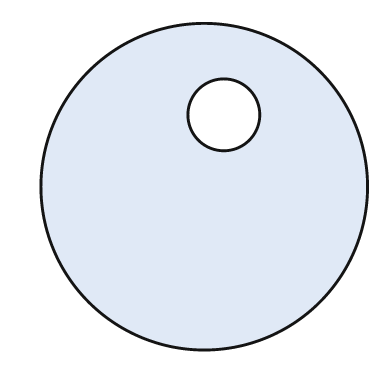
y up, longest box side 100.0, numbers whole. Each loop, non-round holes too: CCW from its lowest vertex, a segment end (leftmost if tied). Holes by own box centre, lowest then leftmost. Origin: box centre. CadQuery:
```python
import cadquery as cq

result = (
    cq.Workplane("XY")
    .moveTo(0.0, 0.0)
    .circle(50.0)
    .moveTo(6.0, 22.0)
    .circle(11.0)
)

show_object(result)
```